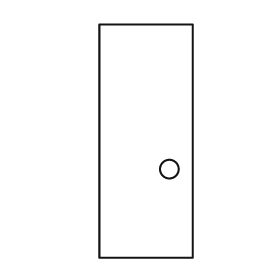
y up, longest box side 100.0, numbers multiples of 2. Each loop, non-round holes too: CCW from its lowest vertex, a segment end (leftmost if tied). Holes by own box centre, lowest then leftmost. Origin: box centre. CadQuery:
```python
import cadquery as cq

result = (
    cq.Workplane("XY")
    .moveTo(-20.0, -50.0)
    .lineTo(20.0, -50.0)
    .lineTo(20.0, 50.0)
    .lineTo(-20.0, 50.0)
    .close()
    .moveTo(10.0, -12.0)
    .circle(4.0)
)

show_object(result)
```